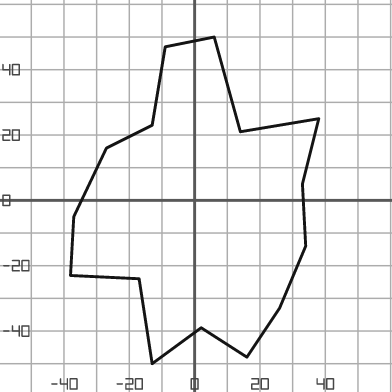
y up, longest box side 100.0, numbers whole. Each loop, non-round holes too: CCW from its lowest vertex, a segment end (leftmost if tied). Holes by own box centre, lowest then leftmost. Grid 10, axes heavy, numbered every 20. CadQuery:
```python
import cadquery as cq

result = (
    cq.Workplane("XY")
    .moveTo(-13.0, -50.0)
    .lineTo(2.0, -39.0)
    .lineTo(16.0, -48.0)
    .lineTo(26.0, -33.0)
    .lineTo(34.0, -14.0)
    .lineTo(33.0, 5.0)
    .lineTo(38.0, 25.0)
    .lineTo(14.0, 21.0)
    .lineTo(6.0, 50.0)
    .lineTo(-9.0, 47.0)
    .lineTo(-13.0, 23.0)
    .lineTo(-27.0, 16.0)
    .lineTo(-37.0, -5.0)
    .lineTo(-38.0, -23.0)
    .lineTo(-17.0, -24.0)
    .close()
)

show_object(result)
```